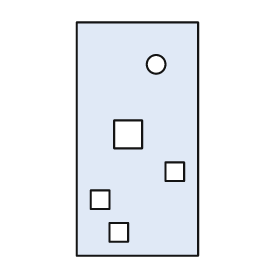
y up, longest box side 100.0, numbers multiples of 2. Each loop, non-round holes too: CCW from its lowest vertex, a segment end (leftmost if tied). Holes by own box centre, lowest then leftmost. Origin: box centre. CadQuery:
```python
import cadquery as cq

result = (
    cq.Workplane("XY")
    .moveTo(-26.0, -50.0)
    .lineTo(26.0, -50.0)
    .lineTo(26.0, 50.0)
    .lineTo(-26.0, 50.0)
    .close()
    .moveTo(-12.0, -44.0)
    .lineTo(-4.0, -44.0)
    .lineTo(-4.0, -36.0)
    .lineTo(-12.0, -36.0)
    .close()
    .moveTo(-20.0, -30.0)
    .lineTo(-12.0, -30.0)
    .lineTo(-12.0, -22.0)
    .lineTo(-20.0, -22.0)
    .close()
    .moveTo(12.0, -18.0)
    .lineTo(20.0, -18.0)
    .lineTo(20.0, -10.0)
    .lineTo(12.0, -10.0)
    .close()
    .moveTo(-10.0, -4.0)
    .lineTo(2.0, -4.0)
    .lineTo(2.0, 8.0)
    .lineTo(-10.0, 8.0)
    .close()
    .moveTo(8.0, 32.0)
    .circle(4.0)
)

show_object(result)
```